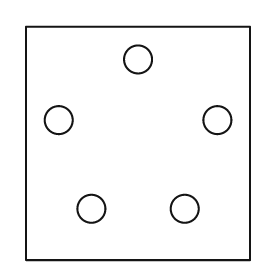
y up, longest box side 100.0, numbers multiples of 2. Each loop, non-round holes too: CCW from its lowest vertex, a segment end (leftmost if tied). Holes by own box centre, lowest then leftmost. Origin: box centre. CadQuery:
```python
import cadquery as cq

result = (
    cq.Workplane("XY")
    .moveTo(-48.0, -50.0)
    .lineTo(48.0, -50.0)
    .lineTo(48.0, 50.0)
    .lineTo(-48.0, 50.0)
    .close()
    .moveTo(-20.0, -28.0)
    .circle(6.0)
    .moveTo(20.0, -28.0)
    .circle(6.0)
    .moveTo(-34.0, 10.0)
    .circle(6.0)
    .moveTo(34.0, 10.0)
    .circle(6.0)
    .moveTo(0.0, 36.0)
    .circle(6.0)
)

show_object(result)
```